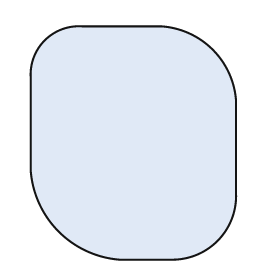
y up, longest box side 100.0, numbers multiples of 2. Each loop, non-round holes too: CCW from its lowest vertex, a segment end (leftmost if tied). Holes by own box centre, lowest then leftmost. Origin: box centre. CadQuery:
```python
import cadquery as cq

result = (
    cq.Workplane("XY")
    .moveTo(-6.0, -50.0)
    .lineTo(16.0, -50.0)
    .threePointArc((36.0, -42.0), (44.0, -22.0))
    .lineTo(44.0, 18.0)
    .threePointArc((34.0, 40.0), (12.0, 50.0))
    .lineTo(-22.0, 50.0)
    .threePointArc((-38.0, 44.0), (-44.0, 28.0))
    .lineTo(-44.0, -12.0)
    .threePointArc((-32.0, -38.0), (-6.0, -50.0))
    .close()
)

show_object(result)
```